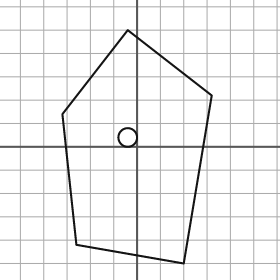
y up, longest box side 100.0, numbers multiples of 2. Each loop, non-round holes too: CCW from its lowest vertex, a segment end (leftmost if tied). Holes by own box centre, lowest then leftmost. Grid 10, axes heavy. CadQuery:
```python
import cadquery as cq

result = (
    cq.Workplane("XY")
    .moveTo(20.0, -50.0)
    .lineTo(32.0, 22.0)
    .lineTo(-4.0, 50.0)
    .lineTo(-32.0, 14.0)
    .lineTo(-26.0, -42.0)
    .close()
    .moveTo(-4.0, 4.0)
    .circle(4.0)
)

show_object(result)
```